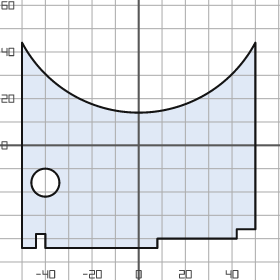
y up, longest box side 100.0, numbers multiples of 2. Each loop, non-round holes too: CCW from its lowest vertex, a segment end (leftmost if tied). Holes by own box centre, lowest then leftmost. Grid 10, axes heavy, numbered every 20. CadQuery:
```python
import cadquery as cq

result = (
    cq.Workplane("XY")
    .moveTo(-50.0, -44.0)
    .lineTo(-44.0, -44.0)
    .lineTo(-44.0, -38.0)
    .lineTo(-40.0, -38.0)
    .lineTo(-40.0, -44.0)
    .lineTo(8.0, -44.0)
    .lineTo(8.0, -40.0)
    .lineTo(42.0, -40.0)
    .lineTo(42.0, -36.0)
    .lineTo(50.0, -36.0)
    .lineTo(50.0, 44.0)
    .threePointArc((0.0, 14.0), (-50.0, 44.0))
    .close()
    .moveTo(-40.0, -16.0)
    .circle(6.0)
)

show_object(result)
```